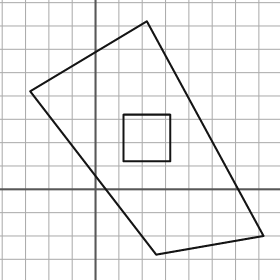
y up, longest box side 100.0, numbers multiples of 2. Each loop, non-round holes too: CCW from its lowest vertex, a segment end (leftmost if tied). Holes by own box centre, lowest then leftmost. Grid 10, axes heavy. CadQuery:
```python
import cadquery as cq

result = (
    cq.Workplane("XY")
    .moveTo(26.0, -28.0)
    .lineTo(72.0, -20.0)
    .lineTo(22.0, 72.0)
    .lineTo(-28.0, 42.0)
    .close()
    .moveTo(12.0, 12.0)
    .lineTo(32.0, 12.0)
    .lineTo(32.0, 32.0)
    .lineTo(12.0, 32.0)
    .close()
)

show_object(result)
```